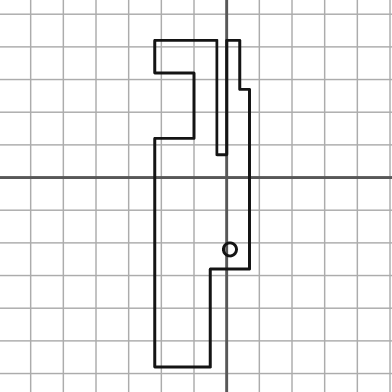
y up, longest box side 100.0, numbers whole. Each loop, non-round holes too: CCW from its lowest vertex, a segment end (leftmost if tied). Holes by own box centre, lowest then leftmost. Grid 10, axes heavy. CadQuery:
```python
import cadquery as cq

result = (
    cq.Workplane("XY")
    .moveTo(-22.0, -58.0)
    .lineTo(-5.0, -58.0)
    .lineTo(-5.0, -28.0)
    .lineTo(7.0, -28.0)
    .lineTo(7.0, 27.0)
    .lineTo(4.0, 27.0)
    .lineTo(4.0, 42.0)
    .lineTo(0.0, 42.0)
    .lineTo(0.0, 7.0)
    .lineTo(-3.0, 7.0)
    .lineTo(-3.0, 42.0)
    .lineTo(-22.0, 42.0)
    .lineTo(-22.0, 32.0)
    .lineTo(-10.0, 32.0)
    .lineTo(-10.0, 12.0)
    .lineTo(-22.0, 12.0)
    .close()
    .moveTo(1.0, -22.0)
    .circle(2.0)
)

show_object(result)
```